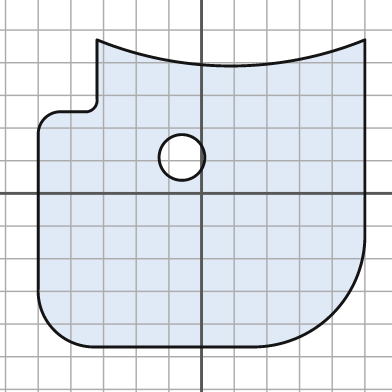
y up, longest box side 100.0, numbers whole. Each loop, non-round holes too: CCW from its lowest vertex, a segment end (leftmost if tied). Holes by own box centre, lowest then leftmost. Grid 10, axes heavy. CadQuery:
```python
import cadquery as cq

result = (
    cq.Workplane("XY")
    .moveTo(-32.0, -47.0)
    .lineTo(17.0, -47.0)
    .threePointArc((40.0, -37.0), (50.0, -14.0))
    .lineTo(50.0, 47.0)
    .threePointArc((9.0, 39.0), (-32.0, 47.0))
    .lineTo(-32.0, 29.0)
    .threePointArc((-33.0, 26.0), (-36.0, 25.0))
    .lineTo(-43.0, 25.0)
    .threePointArc((-48.0, 23.0), (-50.0, 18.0))
    .lineTo(-50.0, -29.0)
    .threePointArc((-45.0, -42.0), (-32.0, -47.0))
    .close()
    .moveTo(-6.0, 11.0)
    .circle(7.0)
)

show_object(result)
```